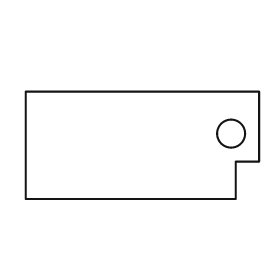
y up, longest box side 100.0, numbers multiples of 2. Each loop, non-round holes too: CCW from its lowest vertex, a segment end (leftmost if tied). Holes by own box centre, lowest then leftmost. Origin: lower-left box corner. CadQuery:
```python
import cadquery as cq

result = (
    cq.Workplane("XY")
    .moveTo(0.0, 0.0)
    .lineTo(90.0, 0.0)
    .lineTo(90.0, 16.0)
    .lineTo(100.0, 16.0)
    .lineTo(100.0, 46.0)
    .lineTo(0.0, 46.0)
    .close()
    .moveTo(88.0, 28.0)
    .circle(6.0)
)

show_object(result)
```